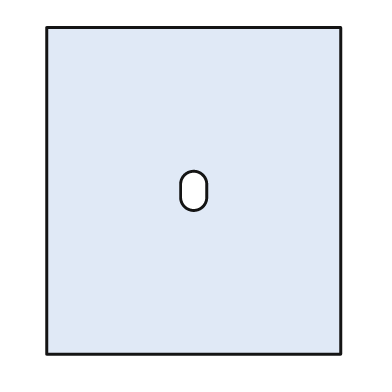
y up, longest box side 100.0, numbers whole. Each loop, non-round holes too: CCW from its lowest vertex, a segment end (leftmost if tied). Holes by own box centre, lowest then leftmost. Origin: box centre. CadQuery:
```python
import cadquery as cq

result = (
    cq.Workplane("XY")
    .moveTo(-45.0, -50.0)
    .lineTo(45.0, -50.0)
    .lineTo(45.0, 50.0)
    .lineTo(-45.0, 50.0)
    .close()
    .moveTo(-4.0, -2.0)
    .threePointArc((0.0, -6.0), (4.0, -2.0))
    .lineTo(4.0, 2.0)
    .threePointArc((0.0, 6.0), (-4.0, 2.0))
    .close()
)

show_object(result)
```